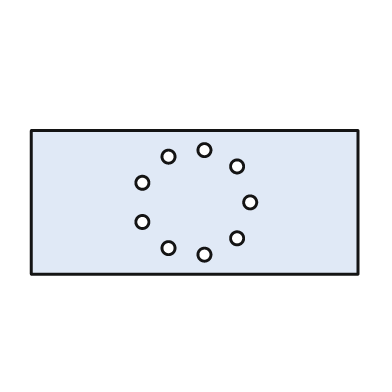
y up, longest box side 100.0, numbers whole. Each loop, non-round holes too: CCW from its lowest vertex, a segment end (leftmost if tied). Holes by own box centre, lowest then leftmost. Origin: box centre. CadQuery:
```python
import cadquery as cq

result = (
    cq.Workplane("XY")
    .moveTo(-50.0, -22.0)
    .lineTo(50.0, -22.0)
    .lineTo(50.0, 22.0)
    .lineTo(-50.0, 22.0)
    .close()
    .moveTo(3.0, -16.0)
    .circle(2.0)
    .moveTo(-8.0, -14.0)
    .circle(2.0)
    .moveTo(13.0, -11.0)
    .circle(2.0)
    .moveTo(-16.0, -6.0)
    .circle(2.0)
    .moveTo(17.0, 0.0)
    .circle(2.0)
    .moveTo(-16.0, 6.0)
    .circle(2.0)
    .moveTo(13.0, 11.0)
    .circle(2.0)
    .moveTo(-8.0, 14.0)
    .circle(2.0)
    .moveTo(3.0, 16.0)
    .circle(2.0)
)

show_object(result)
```